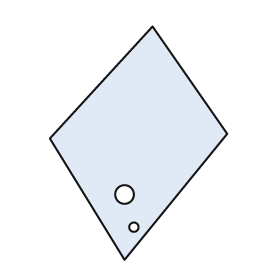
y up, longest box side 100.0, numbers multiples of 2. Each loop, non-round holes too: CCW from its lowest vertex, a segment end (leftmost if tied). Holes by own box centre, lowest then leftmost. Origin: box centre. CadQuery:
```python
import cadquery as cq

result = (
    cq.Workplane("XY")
    .moveTo(-6.0, -50.0)
    .lineTo(38.0, 4.0)
    .lineTo(6.0, 50.0)
    .lineTo(-38.0, 2.0)
    .close()
    .moveTo(-2.0, -36.0)
    .circle(2.0)
    .moveTo(-6.0, -22.0)
    .circle(4.0)
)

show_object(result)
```